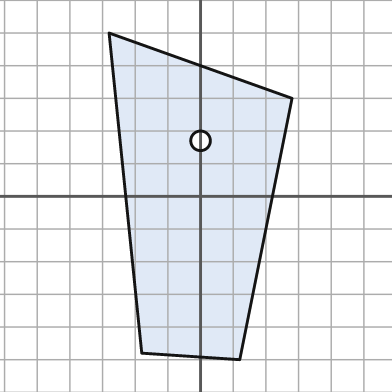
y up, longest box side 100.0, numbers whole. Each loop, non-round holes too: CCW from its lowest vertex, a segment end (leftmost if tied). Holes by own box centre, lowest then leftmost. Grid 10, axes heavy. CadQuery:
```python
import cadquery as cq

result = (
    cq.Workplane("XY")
    .moveTo(12.0, -50.0)
    .lineTo(28.0, 30.0)
    .lineTo(-28.0, 50.0)
    .lineTo(-18.0, -48.0)
    .close()
    .moveTo(0.0, 17.0)
    .circle(3.0)
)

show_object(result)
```